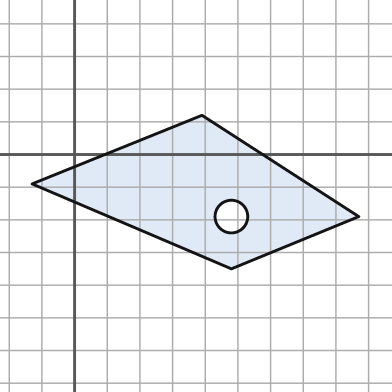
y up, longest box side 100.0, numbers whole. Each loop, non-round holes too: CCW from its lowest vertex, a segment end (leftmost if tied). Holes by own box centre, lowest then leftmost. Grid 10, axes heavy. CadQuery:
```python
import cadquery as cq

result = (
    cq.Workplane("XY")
    .moveTo(48.0, -35.0)
    .lineTo(87.0, -19.0)
    .lineTo(39.0, 12.0)
    .lineTo(-13.0, -9.0)
    .close()
    .moveTo(48.0, -19.0)
    .circle(5.0)
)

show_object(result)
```